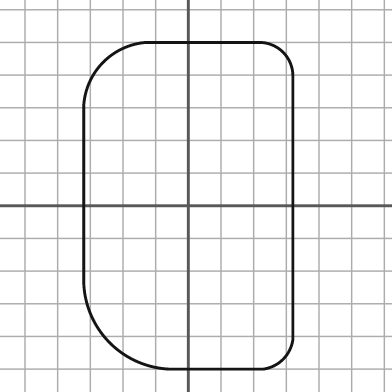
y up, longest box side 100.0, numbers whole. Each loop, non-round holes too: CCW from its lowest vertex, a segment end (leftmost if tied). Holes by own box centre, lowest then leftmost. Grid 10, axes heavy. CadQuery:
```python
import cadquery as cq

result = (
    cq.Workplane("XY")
    .moveTo(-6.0, -50.0)
    .lineTo(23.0, -50.0)
    .threePointArc((29.0, -47.0), (32.0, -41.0))
    .lineTo(32.0, 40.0)
    .threePointArc((29.0, 47.0), (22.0, 50.0))
    .lineTo(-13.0, 50.0)
    .threePointArc((-26.0, 44.0), (-32.0, 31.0))
    .lineTo(-32.0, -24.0)
    .threePointArc((-24.0, -42.0), (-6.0, -50.0))
    .close()
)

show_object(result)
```